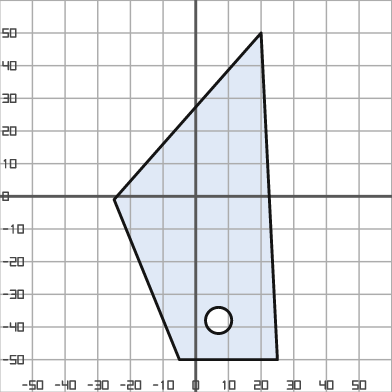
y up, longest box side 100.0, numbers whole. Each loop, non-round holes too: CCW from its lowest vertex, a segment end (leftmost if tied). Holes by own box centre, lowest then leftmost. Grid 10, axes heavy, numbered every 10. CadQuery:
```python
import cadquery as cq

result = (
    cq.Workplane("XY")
    .moveTo(-5.0, -50.0)
    .lineTo(25.0, -50.0)
    .lineTo(20.0, 50.0)
    .lineTo(-25.0, -1.0)
    .close()
    .moveTo(7.0, -38.0)
    .circle(4.0)
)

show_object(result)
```